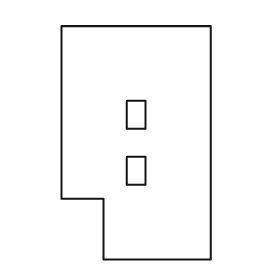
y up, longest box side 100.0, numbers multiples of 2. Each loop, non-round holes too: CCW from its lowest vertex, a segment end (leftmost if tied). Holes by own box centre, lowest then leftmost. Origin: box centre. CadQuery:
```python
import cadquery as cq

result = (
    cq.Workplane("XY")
    .moveTo(-14.0, -50.0)
    .lineTo(32.0, -50.0)
    .lineTo(32.0, 50.0)
    .lineTo(-32.0, 50.0)
    .lineTo(-32.0, -24.0)
    .lineTo(-14.0, -24.0)
    .close()
    .moveTo(-4.0, -18.0)
    .lineTo(4.0, -18.0)
    .lineTo(4.0, -6.0)
    .lineTo(-4.0, -6.0)
    .close()
    .moveTo(-4.0, 6.0)
    .lineTo(4.0, 6.0)
    .lineTo(4.0, 18.0)
    .lineTo(-4.0, 18.0)
    .close()
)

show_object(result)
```